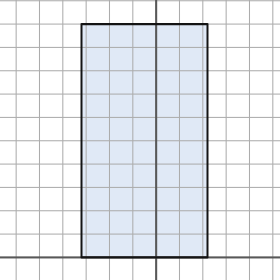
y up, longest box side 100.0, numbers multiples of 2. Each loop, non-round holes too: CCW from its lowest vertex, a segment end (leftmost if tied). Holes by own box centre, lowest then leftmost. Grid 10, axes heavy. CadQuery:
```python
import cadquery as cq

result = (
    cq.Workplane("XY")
    .moveTo(-32.0, 0.0)
    .lineTo(22.0, 0.0)
    .lineTo(22.0, 100.0)
    .lineTo(-32.0, 100.0)
    .close()
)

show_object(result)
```